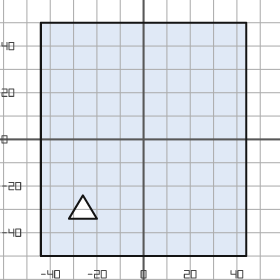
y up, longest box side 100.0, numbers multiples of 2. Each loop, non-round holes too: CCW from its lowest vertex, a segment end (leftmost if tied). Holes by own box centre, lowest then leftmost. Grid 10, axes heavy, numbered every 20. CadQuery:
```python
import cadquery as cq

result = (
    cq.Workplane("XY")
    .moveTo(-44.0, -50.0)
    .lineTo(44.0, -50.0)
    .lineTo(44.0, 50.0)
    .lineTo(-44.0, 50.0)
    .close()
    .moveTo(-32.0, -34.0)
    .lineTo(-20.0, -34.0)
    .lineTo(-26.0, -24.0)
    .close()
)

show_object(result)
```